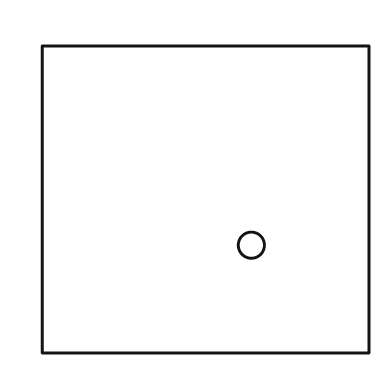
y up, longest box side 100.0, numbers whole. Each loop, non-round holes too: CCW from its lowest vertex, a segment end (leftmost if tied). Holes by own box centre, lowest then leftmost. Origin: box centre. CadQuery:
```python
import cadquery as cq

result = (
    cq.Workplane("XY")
    .moveTo(-50.0, -47.0)
    .lineTo(50.0, -47.0)
    .lineTo(50.0, 47.0)
    .lineTo(-50.0, 47.0)
    .close()
    .moveTo(14.0, -14.0)
    .circle(4.0)
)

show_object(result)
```